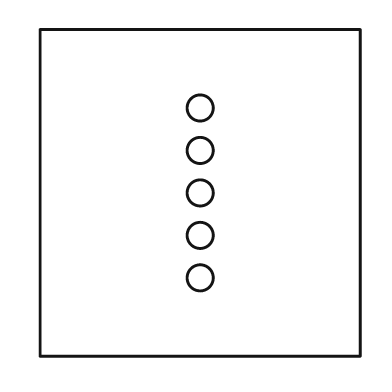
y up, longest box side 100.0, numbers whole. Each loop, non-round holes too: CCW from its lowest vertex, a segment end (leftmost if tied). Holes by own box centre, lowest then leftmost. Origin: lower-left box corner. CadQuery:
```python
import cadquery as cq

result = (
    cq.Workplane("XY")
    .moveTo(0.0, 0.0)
    .lineTo(98.0, 0.0)
    .lineTo(98.0, 100.0)
    .lineTo(0.0, 100.0)
    .close()
    .moveTo(49.0, 24.0)
    .circle(4.0)
    .moveTo(49.0, 37.0)
    .circle(4.0)
    .moveTo(49.0, 50.0)
    .circle(4.0)
    .moveTo(49.0, 63.0)
    .circle(4.0)
    .moveTo(49.0, 76.0)
    .circle(4.0)
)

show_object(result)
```